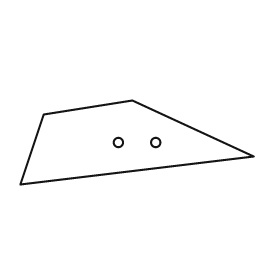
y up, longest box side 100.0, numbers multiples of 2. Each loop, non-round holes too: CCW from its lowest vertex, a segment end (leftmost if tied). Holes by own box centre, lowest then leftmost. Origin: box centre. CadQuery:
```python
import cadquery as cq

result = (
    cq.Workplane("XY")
    .moveTo(-50.0, -18.0)
    .lineTo(50.0, -6.0)
    .lineTo(-2.0, 18.0)
    .lineTo(-40.0, 12.0)
    .close()
    .moveTo(-8.0, 0.0)
    .circle(2.0)
    .moveTo(8.0, 0.0)
    .circle(2.0)
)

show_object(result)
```